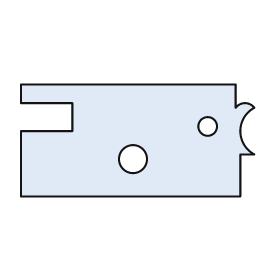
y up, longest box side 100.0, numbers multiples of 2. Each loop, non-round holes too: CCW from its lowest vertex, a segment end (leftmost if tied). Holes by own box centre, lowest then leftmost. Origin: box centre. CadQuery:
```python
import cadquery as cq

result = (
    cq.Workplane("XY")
    .moveTo(-50.0, -24.0)
    .lineTo(44.0, -24.0)
    .lineTo(44.0, -6.0)
    .lineTo(50.0, -6.0)
    .threePointArc((44.0, 4.0), (50.0, 14.0))
    .threePointArc((46.0, 16.0), (42.0, 14.0))
    .lineTo(42.0, 24.0)
    .lineTo(-50.0, 24.0)
    .lineTo(-50.0, 16.0)
    .lineTo(-28.0, 16.0)
    .lineTo(-28.0, 4.0)
    .lineTo(-50.0, 4.0)
    .close()
    .moveTo(-2.0, -8.0)
    .circle(6.0)
    .moveTo(30.0, 6.0)
    .circle(4.0)
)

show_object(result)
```